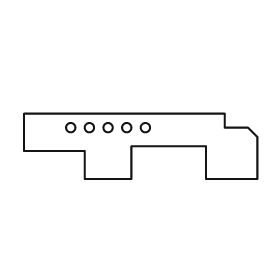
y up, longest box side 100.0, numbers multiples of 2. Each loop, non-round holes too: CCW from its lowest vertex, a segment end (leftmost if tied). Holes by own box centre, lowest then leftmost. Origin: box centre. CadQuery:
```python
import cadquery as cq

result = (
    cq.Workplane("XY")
    .moveTo(-24.0, -14.0)
    .lineTo(-4.0, -14.0)
    .lineTo(-4.0, 0.0)
    .lineTo(28.0, 0.0)
    .lineTo(28.0, -14.0)
    .lineTo(50.0, -14.0)
    .lineTo(50.0, 4.0)
    .lineTo(46.0, 8.0)
    .lineTo(36.0, 8.0)
    .lineTo(36.0, 14.0)
    .lineTo(-50.0, 14.0)
    .lineTo(-50.0, -2.0)
    .lineTo(-24.0, -2.0)
    .close()
    .moveTo(-30.0, 8.0)
    .circle(2.0)
    .moveTo(-22.0, 8.0)
    .circle(2.0)
    .moveTo(-14.0, 8.0)
    .circle(2.0)
    .moveTo(-6.0, 8.0)
    .circle(2.0)
    .moveTo(2.0, 8.0)
    .circle(2.0)
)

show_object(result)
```